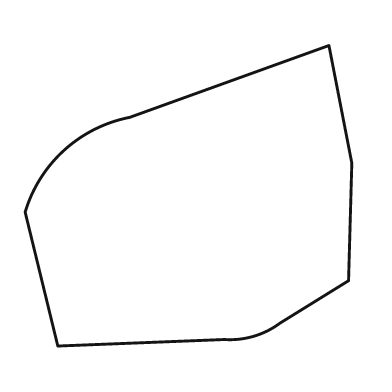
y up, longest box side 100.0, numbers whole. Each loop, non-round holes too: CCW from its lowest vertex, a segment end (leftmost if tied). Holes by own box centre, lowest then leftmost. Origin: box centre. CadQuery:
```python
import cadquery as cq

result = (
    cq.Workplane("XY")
    .moveTo(-40.0, -46.0)
    .lineTo(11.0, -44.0)
    .threePointArc((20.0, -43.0), (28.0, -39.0))
    .lineTo(49.0, -26.0)
    .lineTo(50.0, 10.0)
    .lineTo(43.0, 46.0)
    .lineTo(-18.0, 24.0)
    .threePointArc((-38.0, 14.0), (-50.0, -5.0))
    .close()
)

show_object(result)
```